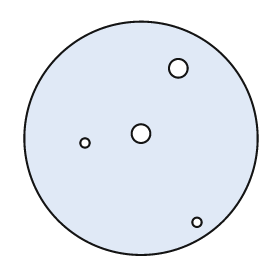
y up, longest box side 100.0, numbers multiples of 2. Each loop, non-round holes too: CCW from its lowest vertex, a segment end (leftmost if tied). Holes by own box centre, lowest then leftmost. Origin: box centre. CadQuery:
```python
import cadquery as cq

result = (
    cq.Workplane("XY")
    .moveTo(0.0, 0.0)
    .circle(50.0)
    .moveTo(24.0, -36.0)
    .circle(2.0)
    .moveTo(-24.0, -2.0)
    .circle(2.0)
    .moveTo(0.0, 2.0)
    .circle(4.0)
    .moveTo(16.0, 30.0)
    .circle(4.0)
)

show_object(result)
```